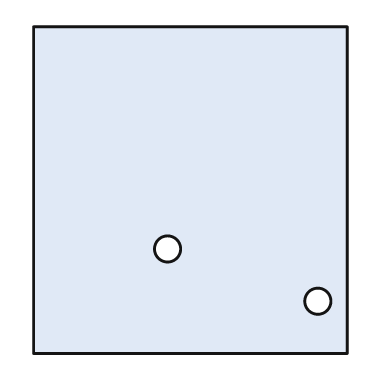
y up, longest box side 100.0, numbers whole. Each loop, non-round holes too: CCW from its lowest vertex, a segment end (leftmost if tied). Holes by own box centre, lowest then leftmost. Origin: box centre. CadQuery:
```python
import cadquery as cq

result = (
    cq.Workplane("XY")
    .moveTo(-48.0, -50.0)
    .lineTo(48.0, -50.0)
    .lineTo(48.0, 50.0)
    .lineTo(-48.0, 50.0)
    .close()
    .moveTo(39.0, -34.0)
    .circle(4.0)
    .moveTo(-7.0, -18.0)
    .circle(4.0)
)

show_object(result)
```